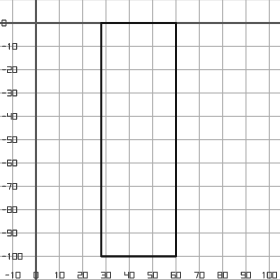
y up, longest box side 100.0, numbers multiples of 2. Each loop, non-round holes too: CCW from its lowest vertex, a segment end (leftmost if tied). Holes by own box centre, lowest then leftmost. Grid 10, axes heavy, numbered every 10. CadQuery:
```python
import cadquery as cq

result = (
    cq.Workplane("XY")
    .moveTo(28.0, -100.0)
    .lineTo(60.0, -100.0)
    .lineTo(60.0, 0.0)
    .lineTo(28.0, 0.0)
    .close()
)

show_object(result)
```